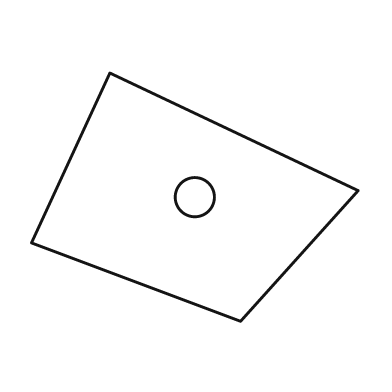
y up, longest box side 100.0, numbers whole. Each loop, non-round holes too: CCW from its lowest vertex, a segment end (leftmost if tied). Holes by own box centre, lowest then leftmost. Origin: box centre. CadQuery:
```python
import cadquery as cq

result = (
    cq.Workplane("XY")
    .moveTo(14.0, -38.0)
    .lineTo(50.0, 2.0)
    .lineTo(-26.0, 38.0)
    .lineTo(-50.0, -14.0)
    .close()
    .moveTo(0.0, 0.0)
    .circle(6.0)
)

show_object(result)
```